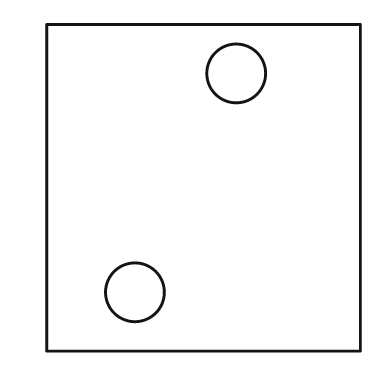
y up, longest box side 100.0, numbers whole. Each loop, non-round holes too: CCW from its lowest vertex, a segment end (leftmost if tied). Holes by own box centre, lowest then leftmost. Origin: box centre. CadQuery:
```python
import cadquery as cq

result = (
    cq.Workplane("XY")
    .moveTo(-48.0, -50.0)
    .lineTo(48.0, -50.0)
    .lineTo(48.0, 50.0)
    .lineTo(-48.0, 50.0)
    .close()
    .moveTo(-21.0, -32.0)
    .circle(9.0)
    .moveTo(10.0, 35.0)
    .circle(9.0)
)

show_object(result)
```